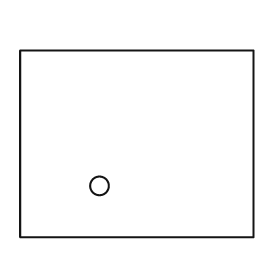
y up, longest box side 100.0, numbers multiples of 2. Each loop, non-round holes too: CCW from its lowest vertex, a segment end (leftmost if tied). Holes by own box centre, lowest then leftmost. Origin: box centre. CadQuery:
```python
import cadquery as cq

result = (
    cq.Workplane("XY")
    .moveTo(-50.0, -40.0)
    .lineTo(50.0, -40.0)
    .lineTo(50.0, 40.0)
    .lineTo(-50.0, 40.0)
    .close()
    .moveTo(-16.0, -18.0)
    .circle(4.0)
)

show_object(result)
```